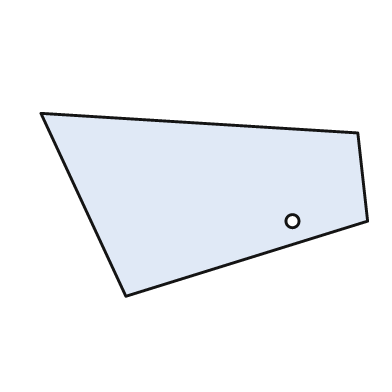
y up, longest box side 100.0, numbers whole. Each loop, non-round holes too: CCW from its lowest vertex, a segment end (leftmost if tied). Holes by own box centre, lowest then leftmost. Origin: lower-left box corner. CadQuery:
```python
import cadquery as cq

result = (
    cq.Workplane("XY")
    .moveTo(26.0, 0.0)
    .lineTo(100.0, 23.0)
    .lineTo(97.0, 50.0)
    .lineTo(0.0, 56.0)
    .close()
    .moveTo(77.0, 23.0)
    .circle(2.0)
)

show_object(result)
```